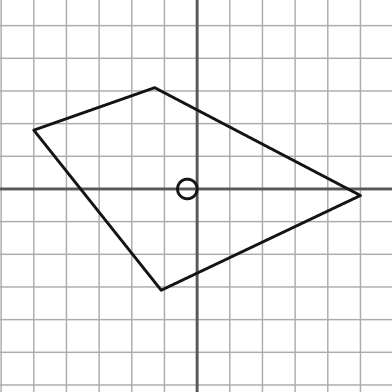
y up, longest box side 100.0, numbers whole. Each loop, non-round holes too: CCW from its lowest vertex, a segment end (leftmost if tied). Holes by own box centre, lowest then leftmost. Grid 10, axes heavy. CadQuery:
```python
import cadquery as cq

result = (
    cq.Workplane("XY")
    .moveTo(-11.0, -31.0)
    .lineTo(50.0, -2.0)
    .lineTo(-13.0, 31.0)
    .lineTo(-50.0, 18.0)
    .close()
    .moveTo(-3.0, 0.0)
    .circle(3.0)
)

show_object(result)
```